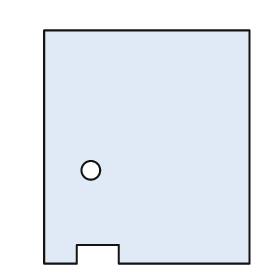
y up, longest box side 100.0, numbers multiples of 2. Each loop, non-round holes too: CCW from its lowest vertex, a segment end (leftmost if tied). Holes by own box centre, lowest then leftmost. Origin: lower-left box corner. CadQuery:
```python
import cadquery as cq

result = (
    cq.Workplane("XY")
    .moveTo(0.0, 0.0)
    .lineTo(14.0, 0.0)
    .lineTo(14.0, 8.0)
    .lineTo(32.0, 8.0)
    .lineTo(32.0, 0.0)
    .lineTo(88.0, 0.0)
    .lineTo(88.0, 100.0)
    .lineTo(0.0, 100.0)
    .close()
    .moveTo(20.0, 40.0)
    .circle(4.0)
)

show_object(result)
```